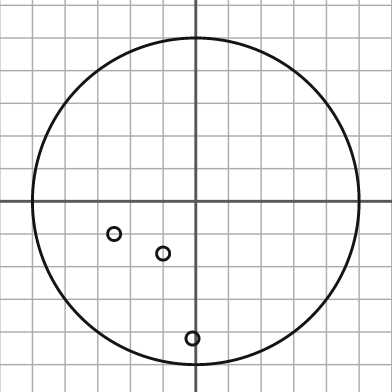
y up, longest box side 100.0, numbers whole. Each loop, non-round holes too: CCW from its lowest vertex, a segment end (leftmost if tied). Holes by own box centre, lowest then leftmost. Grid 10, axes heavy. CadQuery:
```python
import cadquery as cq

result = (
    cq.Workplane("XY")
    .moveTo(0.0, 0.0)
    .circle(50.0)
    .moveTo(-1.0, -42.0)
    .circle(2.0)
    .moveTo(-10.0, -16.0)
    .circle(2.0)
    .moveTo(-25.0, -10.0)
    .circle(2.0)
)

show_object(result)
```